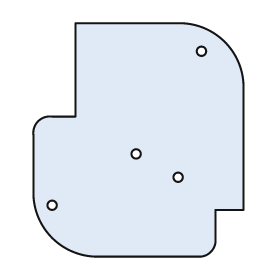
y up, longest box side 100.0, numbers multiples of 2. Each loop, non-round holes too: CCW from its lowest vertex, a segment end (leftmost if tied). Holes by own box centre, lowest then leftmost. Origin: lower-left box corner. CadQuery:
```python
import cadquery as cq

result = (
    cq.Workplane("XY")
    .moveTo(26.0, 0.0)
    .lineTo(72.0, 0.0)
    .threePointArc((76.0, 2.0), (78.0, 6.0))
    .lineTo(78.0, 20.0)
    .lineTo(90.0, 20.0)
    .lineTo(90.0, 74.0)
    .threePointArc((82.0, 92.0), (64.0, 100.0))
    .lineTo(18.0, 100.0)
    .lineTo(18.0, 60.0)
    .lineTo(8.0, 60.0)
    .threePointArc((2.0, 58.0), (0.0, 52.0))
    .lineTo(0.0, 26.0)
    .threePointArc((8.0, 8.0), (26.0, 0.0))
    .close()
    .moveTo(8.0, 22.0)
    .circle(2.0)
    .moveTo(62.0, 34.0)
    .circle(2.0)
    .moveTo(44.0, 44.0)
    .circle(2.0)
    .moveTo(72.0, 88.0)
    .circle(2.0)
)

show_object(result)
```